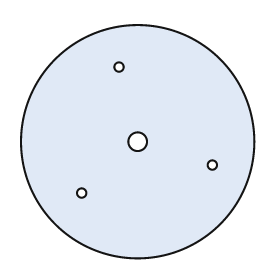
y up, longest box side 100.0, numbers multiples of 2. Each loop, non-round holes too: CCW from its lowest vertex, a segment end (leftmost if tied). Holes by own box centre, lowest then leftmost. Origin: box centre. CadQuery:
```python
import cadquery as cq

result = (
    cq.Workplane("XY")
    .moveTo(0.0, 0.0)
    .circle(50.0)
    .moveTo(-24.0, -22.0)
    .circle(2.0)
    .moveTo(32.0, -10.0)
    .circle(2.0)
    .moveTo(0.0, 0.0)
    .circle(4.0)
    .moveTo(-8.0, 32.0)
    .circle(2.0)
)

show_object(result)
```